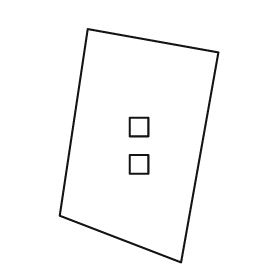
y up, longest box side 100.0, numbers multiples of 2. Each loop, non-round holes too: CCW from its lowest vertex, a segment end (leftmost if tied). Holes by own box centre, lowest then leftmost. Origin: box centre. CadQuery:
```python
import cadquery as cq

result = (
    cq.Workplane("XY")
    .moveTo(18.0, -50.0)
    .lineTo(34.0, 40.0)
    .lineTo(-22.0, 50.0)
    .lineTo(-34.0, -30.0)
    .close()
    .moveTo(-4.0, -12.0)
    .lineTo(4.0, -12.0)
    .lineTo(4.0, -4.0)
    .lineTo(-4.0, -4.0)
    .close()
    .moveTo(-4.0, 4.0)
    .lineTo(4.0, 4.0)
    .lineTo(4.0, 12.0)
    .lineTo(-4.0, 12.0)
    .close()
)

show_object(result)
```